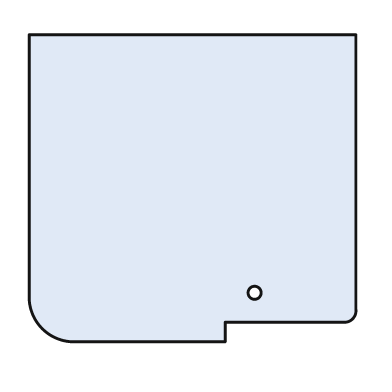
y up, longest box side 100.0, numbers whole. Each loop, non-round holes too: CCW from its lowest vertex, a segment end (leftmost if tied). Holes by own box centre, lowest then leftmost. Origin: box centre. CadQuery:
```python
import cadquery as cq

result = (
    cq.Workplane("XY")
    .moveTo(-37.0, -47.0)
    .lineTo(10.0, -47.0)
    .lineTo(10.0, -41.0)
    .lineTo(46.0, -41.0)
    .threePointArc((49.0, -40.0), (50.0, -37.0))
    .lineTo(50.0, 47.0)
    .lineTo(-50.0, 47.0)
    .lineTo(-50.0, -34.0)
    .threePointArc((-46.0, -43.0), (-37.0, -47.0))
    .close()
    .moveTo(19.0, -32.0)
    .circle(2.0)
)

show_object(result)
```